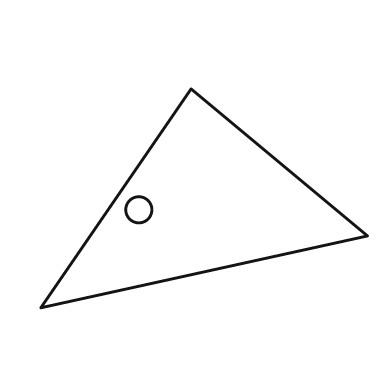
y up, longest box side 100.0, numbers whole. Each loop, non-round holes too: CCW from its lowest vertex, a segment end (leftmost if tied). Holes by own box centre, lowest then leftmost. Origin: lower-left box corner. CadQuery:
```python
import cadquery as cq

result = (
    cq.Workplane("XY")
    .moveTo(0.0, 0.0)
    .lineTo(100.0, 22.0)
    .lineTo(46.0, 67.0)
    .close()
    .moveTo(30.0, 30.0)
    .circle(4.0)
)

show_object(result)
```